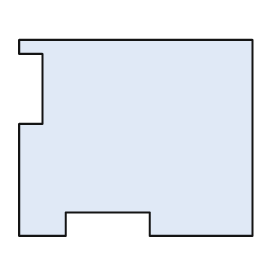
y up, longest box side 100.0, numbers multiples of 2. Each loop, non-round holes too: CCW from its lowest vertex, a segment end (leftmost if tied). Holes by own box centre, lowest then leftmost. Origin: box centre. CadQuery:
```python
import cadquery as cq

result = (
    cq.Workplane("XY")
    .moveTo(-50.0, -42.0)
    .lineTo(-30.0, -42.0)
    .lineTo(-30.0, -32.0)
    .lineTo(6.0, -32.0)
    .lineTo(6.0, -42.0)
    .lineTo(50.0, -42.0)
    .lineTo(50.0, 42.0)
    .lineTo(-50.0, 42.0)
    .lineTo(-50.0, 36.0)
    .lineTo(-40.0, 36.0)
    .lineTo(-40.0, 6.0)
    .lineTo(-50.0, 6.0)
    .close()
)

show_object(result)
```